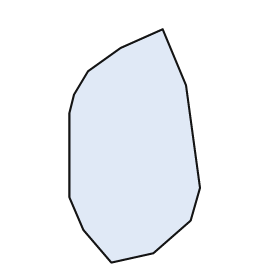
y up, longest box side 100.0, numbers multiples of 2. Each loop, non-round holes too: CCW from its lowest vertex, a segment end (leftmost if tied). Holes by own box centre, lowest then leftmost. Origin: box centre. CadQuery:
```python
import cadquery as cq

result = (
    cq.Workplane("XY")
    .moveTo(-10.0, -50.0)
    .lineTo(8.0, -46.0)
    .lineTo(24.0, -32.0)
    .lineTo(28.0, -18.0)
    .lineTo(22.0, 26.0)
    .lineTo(12.0, 50.0)
    .lineTo(-6.0, 42.0)
    .lineTo(-20.0, 32.0)
    .lineTo(-26.0, 22.0)
    .lineTo(-28.0, 14.0)
    .lineTo(-28.0, -22.0)
    .lineTo(-22.0, -36.0)
    .close()
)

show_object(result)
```